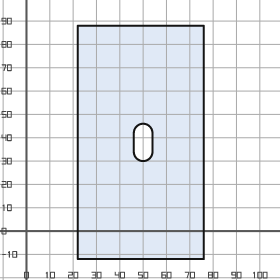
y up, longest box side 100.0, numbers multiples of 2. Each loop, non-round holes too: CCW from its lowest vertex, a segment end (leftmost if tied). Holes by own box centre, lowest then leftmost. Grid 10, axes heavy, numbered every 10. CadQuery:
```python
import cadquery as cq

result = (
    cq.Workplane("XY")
    .moveTo(22.0, -12.0)
    .lineTo(76.0, -12.0)
    .lineTo(76.0, 88.0)
    .lineTo(22.0, 88.0)
    .close()
    .moveTo(46.0, 34.0)
    .threePointArc((50.0, 30.0), (54.0, 34.0))
    .lineTo(54.0, 42.0)
    .threePointArc((50.0, 46.0), (46.0, 42.0))
    .close()
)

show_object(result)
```